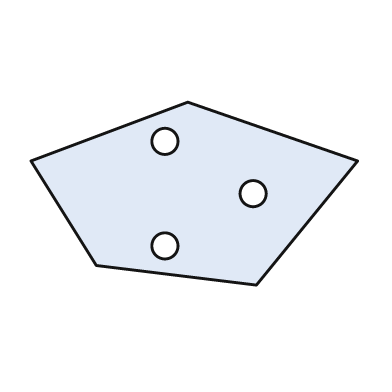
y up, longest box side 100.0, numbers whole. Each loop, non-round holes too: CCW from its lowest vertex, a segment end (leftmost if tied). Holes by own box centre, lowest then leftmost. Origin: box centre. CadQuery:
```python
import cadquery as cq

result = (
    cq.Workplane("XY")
    .moveTo(19.0, -28.0)
    .lineTo(50.0, 10.0)
    .lineTo(-2.0, 28.0)
    .lineTo(-50.0, 10.0)
    .lineTo(-30.0, -22.0)
    .close()
    .moveTo(-9.0, -16.0)
    .circle(4.0)
    .moveTo(18.0, 0.0)
    .circle(4.0)
    .moveTo(-9.0, 16.0)
    .circle(4.0)
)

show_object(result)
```